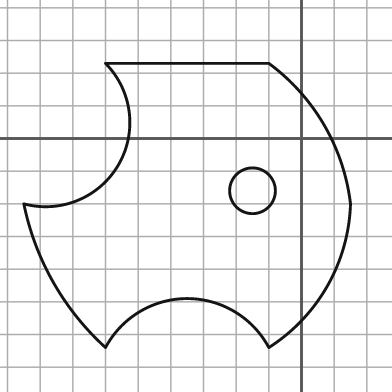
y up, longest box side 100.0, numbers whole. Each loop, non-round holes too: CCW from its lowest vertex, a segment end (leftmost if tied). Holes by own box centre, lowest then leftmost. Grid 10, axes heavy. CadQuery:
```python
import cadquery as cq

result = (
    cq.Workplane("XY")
    .moveTo(-60.0, -64.0)
    .threePointArc((-35.0, -49.0), (-10.0, -64.0))
    .threePointArc((8.0, -45.0), (15.0, -20.0))
    .threePointArc((7.0, 4.0), (-10.0, 23.0))
    .lineTo(-60.0, 23.0)
    .threePointArc((-56.0, -8.0), (-85.0, -20.0))
    .threePointArc((-76.0, -44.0), (-60.0, -64.0))
    .close()
    .moveTo(-15.0, -16.0)
    .circle(7.0)
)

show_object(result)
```